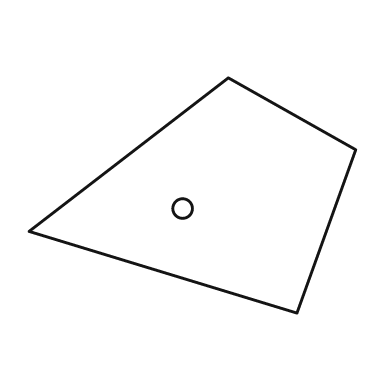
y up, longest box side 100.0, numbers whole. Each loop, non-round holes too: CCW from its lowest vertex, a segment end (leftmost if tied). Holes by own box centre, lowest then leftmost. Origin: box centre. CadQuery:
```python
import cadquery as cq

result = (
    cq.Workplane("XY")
    .moveTo(32.0, -36.0)
    .lineTo(50.0, 14.0)
    .lineTo(11.0, 36.0)
    .lineTo(-50.0, -11.0)
    .close()
    .moveTo(-3.0, -4.0)
    .circle(3.0)
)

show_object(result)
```